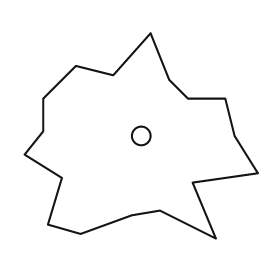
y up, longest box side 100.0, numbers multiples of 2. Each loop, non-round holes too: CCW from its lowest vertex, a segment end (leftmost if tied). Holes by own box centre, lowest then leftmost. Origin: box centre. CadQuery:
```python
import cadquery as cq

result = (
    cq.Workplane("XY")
    .moveTo(32.0, -44.0)
    .lineTo(22.0, -20.0)
    .lineTo(50.0, -16.0)
    .lineTo(40.0, 0.0)
    .lineTo(36.0, 16.0)
    .lineTo(20.0, 16.0)
    .lineTo(12.0, 24.0)
    .lineTo(4.0, 44.0)
    .lineTo(-12.0, 26.0)
    .lineTo(-28.0, 30.0)
    .lineTo(-42.0, 16.0)
    .lineTo(-42.0, 2.0)
    .lineTo(-50.0, -8.0)
    .lineTo(-34.0, -18.0)
    .lineTo(-40.0, -38.0)
    .lineTo(-26.0, -42.0)
    .lineTo(-4.0, -34.0)
    .lineTo(8.0, -32.0)
    .close()
    .moveTo(0.0, 0.0)
    .circle(4.0)
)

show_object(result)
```